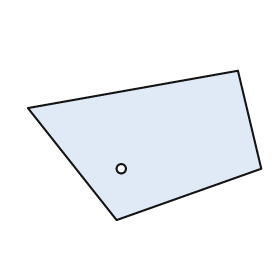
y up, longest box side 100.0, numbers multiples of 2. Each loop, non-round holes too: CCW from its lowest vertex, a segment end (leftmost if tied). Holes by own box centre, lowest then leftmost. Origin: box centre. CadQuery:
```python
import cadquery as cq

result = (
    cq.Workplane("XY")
    .moveTo(-12.0, -32.0)
    .lineTo(50.0, -10.0)
    .lineTo(40.0, 32.0)
    .lineTo(-50.0, 16.0)
    .close()
    .moveTo(-10.0, -10.0)
    .circle(2.0)
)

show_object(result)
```